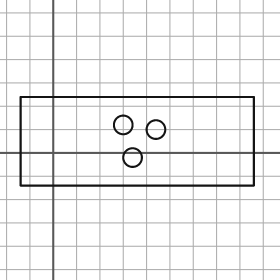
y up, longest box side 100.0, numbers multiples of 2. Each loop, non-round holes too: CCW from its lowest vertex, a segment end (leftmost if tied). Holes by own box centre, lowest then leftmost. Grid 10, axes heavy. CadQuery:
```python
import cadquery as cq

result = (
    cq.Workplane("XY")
    .moveTo(-14.0, -14.0)
    .lineTo(86.0, -14.0)
    .lineTo(86.0, 24.0)
    .lineTo(-14.0, 24.0)
    .close()
    .moveTo(34.0, -2.0)
    .circle(4.0)
    .moveTo(44.0, 10.0)
    .circle(4.0)
    .moveTo(30.0, 12.0)
    .circle(4.0)
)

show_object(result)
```